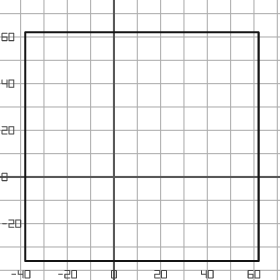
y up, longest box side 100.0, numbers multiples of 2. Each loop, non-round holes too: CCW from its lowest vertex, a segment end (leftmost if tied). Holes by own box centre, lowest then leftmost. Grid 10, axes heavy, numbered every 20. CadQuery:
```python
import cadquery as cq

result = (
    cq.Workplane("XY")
    .moveTo(-38.0, -36.0)
    .lineTo(62.0, -36.0)
    .lineTo(62.0, 62.0)
    .lineTo(-38.0, 62.0)
    .close()
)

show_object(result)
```